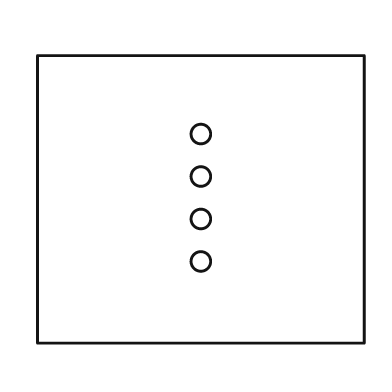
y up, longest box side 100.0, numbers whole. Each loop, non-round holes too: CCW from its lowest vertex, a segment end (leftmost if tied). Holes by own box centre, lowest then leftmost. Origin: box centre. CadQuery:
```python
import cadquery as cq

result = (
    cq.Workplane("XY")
    .moveTo(-50.0, -44.0)
    .lineTo(50.0, -44.0)
    .lineTo(50.0, 44.0)
    .lineTo(-50.0, 44.0)
    .close()
    .moveTo(0.0, -19.0)
    .circle(3.0)
    .moveTo(0.0, -6.0)
    .circle(3.0)
    .moveTo(0.0, 7.0)
    .circle(3.0)
    .moveTo(0.0, 20.0)
    .circle(3.0)
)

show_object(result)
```